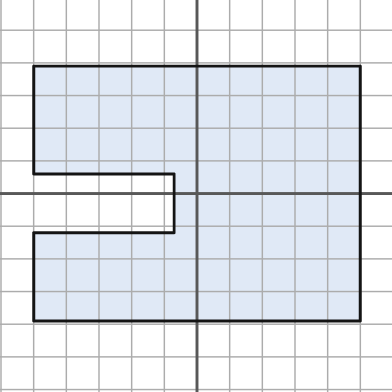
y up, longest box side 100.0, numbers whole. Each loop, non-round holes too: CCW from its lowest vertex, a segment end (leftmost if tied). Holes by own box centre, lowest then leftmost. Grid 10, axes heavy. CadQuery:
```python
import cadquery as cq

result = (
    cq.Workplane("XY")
    .moveTo(-50.0, -39.0)
    .lineTo(50.0, -39.0)
    .lineTo(50.0, 39.0)
    .lineTo(-50.0, 39.0)
    .lineTo(-50.0, 6.0)
    .lineTo(-7.0, 6.0)
    .lineTo(-7.0, -12.0)
    .lineTo(-50.0, -12.0)
    .close()
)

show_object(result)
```